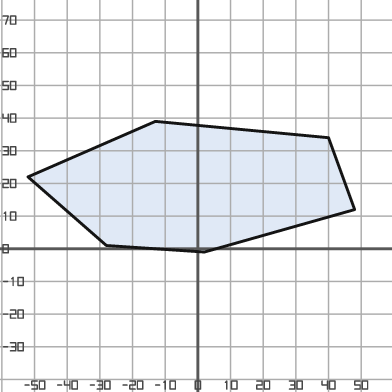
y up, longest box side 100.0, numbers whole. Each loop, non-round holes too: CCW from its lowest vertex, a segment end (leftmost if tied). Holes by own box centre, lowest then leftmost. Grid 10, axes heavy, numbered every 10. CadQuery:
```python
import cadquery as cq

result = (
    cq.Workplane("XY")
    .moveTo(2.0, -1.0)
    .lineTo(48.0, 12.0)
    .lineTo(40.0, 34.0)
    .lineTo(-13.0, 39.0)
    .lineTo(-52.0, 22.0)
    .lineTo(-28.0, 1.0)
    .close()
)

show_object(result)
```